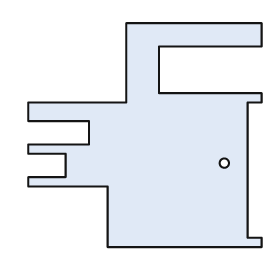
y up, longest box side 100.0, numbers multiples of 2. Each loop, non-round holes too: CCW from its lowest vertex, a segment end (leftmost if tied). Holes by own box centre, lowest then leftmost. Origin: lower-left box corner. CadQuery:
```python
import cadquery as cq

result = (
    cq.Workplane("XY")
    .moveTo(34.0, 0.0)
    .lineTo(100.0, 0.0)
    .lineTo(100.0, 4.0)
    .lineTo(94.0, 4.0)
    .lineTo(94.0, 62.0)
    .lineTo(100.0, 62.0)
    .lineTo(100.0, 66.0)
    .lineTo(56.0, 66.0)
    .lineTo(56.0, 86.0)
    .lineTo(100.0, 86.0)
    .lineTo(100.0, 96.0)
    .lineTo(42.0, 96.0)
    .lineTo(42.0, 62.0)
    .lineTo(0.0, 62.0)
    .lineTo(0.0, 54.0)
    .lineTo(26.0, 54.0)
    .lineTo(26.0, 44.0)
    .lineTo(0.0, 44.0)
    .lineTo(0.0, 40.0)
    .lineTo(16.0, 40.0)
    .lineTo(16.0, 30.0)
    .lineTo(0.0, 30.0)
    .lineTo(0.0, 26.0)
    .lineTo(34.0, 26.0)
    .close()
    .moveTo(84.0, 36.0)
    .circle(2.0)
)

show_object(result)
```